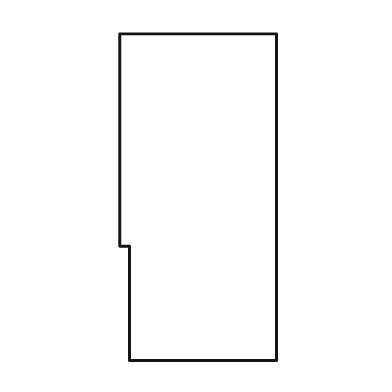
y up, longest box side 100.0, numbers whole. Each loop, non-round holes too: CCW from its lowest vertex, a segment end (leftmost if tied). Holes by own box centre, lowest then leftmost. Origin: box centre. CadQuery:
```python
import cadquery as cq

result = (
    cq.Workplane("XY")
    .moveTo(-21.0, -50.0)
    .lineTo(24.0, -50.0)
    .lineTo(24.0, 50.0)
    .lineTo(-24.0, 50.0)
    .lineTo(-24.0, -15.0)
    .lineTo(-21.0, -15.0)
    .close()
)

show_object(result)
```